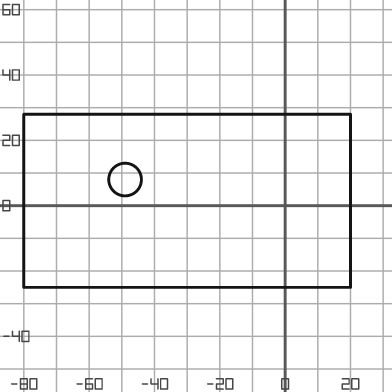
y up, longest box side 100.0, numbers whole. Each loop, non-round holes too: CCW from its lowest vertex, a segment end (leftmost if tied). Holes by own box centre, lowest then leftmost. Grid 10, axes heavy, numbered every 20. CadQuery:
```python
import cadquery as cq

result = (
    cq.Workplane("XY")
    .moveTo(-80.0, -25.0)
    .lineTo(20.0, -25.0)
    .lineTo(20.0, 28.0)
    .lineTo(-80.0, 28.0)
    .close()
    .moveTo(-49.0, 8.0)
    .circle(5.0)
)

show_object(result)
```